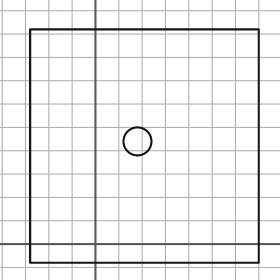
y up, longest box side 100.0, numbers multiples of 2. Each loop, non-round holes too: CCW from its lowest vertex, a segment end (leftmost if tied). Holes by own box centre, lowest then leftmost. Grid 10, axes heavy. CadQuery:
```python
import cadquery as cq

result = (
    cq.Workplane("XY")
    .moveTo(-28.0, -8.0)
    .lineTo(70.0, -8.0)
    .lineTo(70.0, 92.0)
    .lineTo(-28.0, 92.0)
    .close()
    .moveTo(18.0, 44.0)
    .circle(6.0)
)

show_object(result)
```